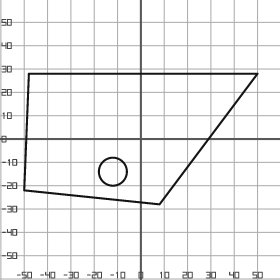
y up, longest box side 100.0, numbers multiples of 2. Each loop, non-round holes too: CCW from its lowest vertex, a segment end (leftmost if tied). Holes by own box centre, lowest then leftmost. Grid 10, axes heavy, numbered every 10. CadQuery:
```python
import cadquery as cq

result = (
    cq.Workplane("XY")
    .moveTo(8.0, -28.0)
    .lineTo(50.0, 28.0)
    .lineTo(-48.0, 28.0)
    .lineTo(-50.0, -22.0)
    .close()
    .moveTo(-12.0, -14.0)
    .circle(6.0)
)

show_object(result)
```